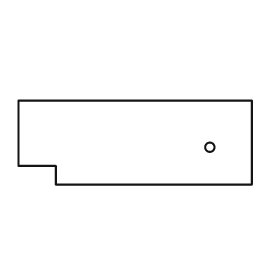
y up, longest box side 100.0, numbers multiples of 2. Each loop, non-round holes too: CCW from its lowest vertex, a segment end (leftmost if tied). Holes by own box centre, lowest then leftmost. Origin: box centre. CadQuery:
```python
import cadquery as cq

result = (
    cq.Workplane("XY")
    .moveTo(-34.0, -18.0)
    .lineTo(50.0, -18.0)
    .lineTo(50.0, 18.0)
    .lineTo(-50.0, 18.0)
    .lineTo(-50.0, -10.0)
    .lineTo(-34.0, -10.0)
    .close()
    .moveTo(32.0, -2.0)
    .circle(2.0)
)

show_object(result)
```